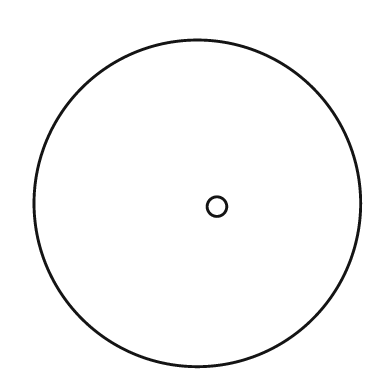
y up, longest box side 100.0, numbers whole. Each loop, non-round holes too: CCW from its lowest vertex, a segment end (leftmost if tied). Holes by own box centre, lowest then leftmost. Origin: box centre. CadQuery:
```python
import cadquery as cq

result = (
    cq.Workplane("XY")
    .moveTo(0.0, 0.0)
    .circle(50.0)
    .moveTo(6.0, -1.0)
    .circle(3.0)
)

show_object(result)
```